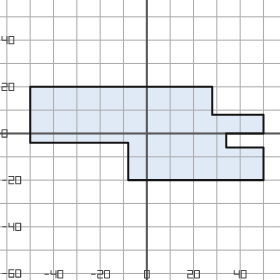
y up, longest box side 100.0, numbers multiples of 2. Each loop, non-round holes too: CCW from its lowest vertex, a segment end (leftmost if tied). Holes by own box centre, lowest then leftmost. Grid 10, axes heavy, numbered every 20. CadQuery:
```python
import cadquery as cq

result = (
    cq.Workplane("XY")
    .moveTo(-8.0, -20.0)
    .lineTo(50.0, -20.0)
    .lineTo(50.0, -6.0)
    .lineTo(34.0, -6.0)
    .lineTo(34.0, 0.0)
    .lineTo(50.0, 0.0)
    .lineTo(50.0, 8.0)
    .lineTo(28.0, 8.0)
    .lineTo(28.0, 20.0)
    .lineTo(-50.0, 20.0)
    .lineTo(-50.0, -4.0)
    .lineTo(-8.0, -4.0)
    .close()
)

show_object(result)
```